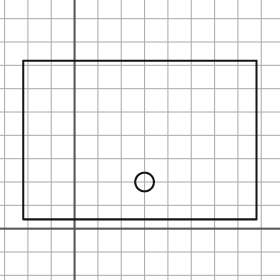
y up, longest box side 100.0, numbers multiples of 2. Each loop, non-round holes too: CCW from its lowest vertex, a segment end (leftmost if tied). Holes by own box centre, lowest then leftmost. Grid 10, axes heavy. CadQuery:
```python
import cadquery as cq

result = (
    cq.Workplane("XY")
    .moveTo(-22.0, 4.0)
    .lineTo(78.0, 4.0)
    .lineTo(78.0, 72.0)
    .lineTo(-22.0, 72.0)
    .close()
    .moveTo(30.0, 20.0)
    .circle(4.0)
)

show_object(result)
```